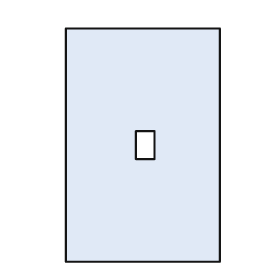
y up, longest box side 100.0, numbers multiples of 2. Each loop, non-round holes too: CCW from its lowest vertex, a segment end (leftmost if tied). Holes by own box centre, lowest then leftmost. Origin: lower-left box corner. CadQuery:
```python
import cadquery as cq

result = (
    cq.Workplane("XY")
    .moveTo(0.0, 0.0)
    .lineTo(66.0, 0.0)
    .lineTo(66.0, 100.0)
    .lineTo(0.0, 100.0)
    .close()
    .moveTo(30.0, 44.0)
    .lineTo(38.0, 44.0)
    .lineTo(38.0, 56.0)
    .lineTo(30.0, 56.0)
    .close()
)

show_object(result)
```